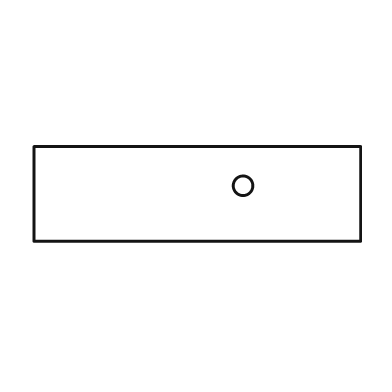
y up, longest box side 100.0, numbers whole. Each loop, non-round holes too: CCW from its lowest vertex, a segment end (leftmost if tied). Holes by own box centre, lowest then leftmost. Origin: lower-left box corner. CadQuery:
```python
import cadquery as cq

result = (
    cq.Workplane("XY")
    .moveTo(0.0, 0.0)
    .lineTo(100.0, 0.0)
    .lineTo(100.0, 29.0)
    .lineTo(0.0, 29.0)
    .close()
    .moveTo(64.0, 17.0)
    .circle(3.0)
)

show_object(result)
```